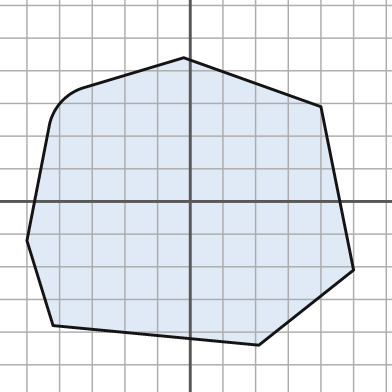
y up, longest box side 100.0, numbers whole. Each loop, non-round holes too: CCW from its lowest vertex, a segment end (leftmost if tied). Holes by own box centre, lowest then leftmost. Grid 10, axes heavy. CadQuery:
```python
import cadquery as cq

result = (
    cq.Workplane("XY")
    .moveTo(21.0, -44.0)
    .lineTo(50.0, -21.0)
    .lineTo(40.0, 29.0)
    .lineTo(-2.0, 44.0)
    .lineTo(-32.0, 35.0)
    .threePointArc((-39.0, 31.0), (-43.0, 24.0))
    .lineTo(-50.0, -12.0)
    .lineTo(-42.0, -38.0)
    .close()
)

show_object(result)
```